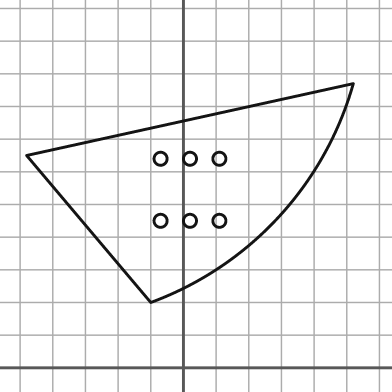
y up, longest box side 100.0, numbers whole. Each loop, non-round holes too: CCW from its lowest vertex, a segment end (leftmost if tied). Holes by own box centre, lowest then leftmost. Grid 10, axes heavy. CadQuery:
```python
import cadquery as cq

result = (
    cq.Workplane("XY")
    .moveTo(-10.0, 20.0)
    .threePointArc((29.0, 46.0), (52.0, 87.0))
    .lineTo(-48.0, 65.0)
    .close()
    .moveTo(-7.0, 45.0)
    .circle(2.0)
    .moveTo(2.0, 45.0)
    .circle(2.0)
    .moveTo(11.0, 45.0)
    .circle(2.0)
    .moveTo(-7.0, 64.0)
    .circle(2.0)
    .moveTo(2.0, 64.0)
    .circle(2.0)
    .moveTo(11.0, 64.0)
    .circle(2.0)
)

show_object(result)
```